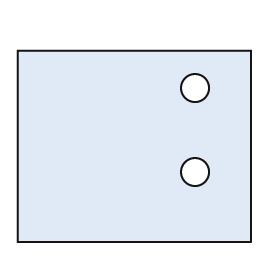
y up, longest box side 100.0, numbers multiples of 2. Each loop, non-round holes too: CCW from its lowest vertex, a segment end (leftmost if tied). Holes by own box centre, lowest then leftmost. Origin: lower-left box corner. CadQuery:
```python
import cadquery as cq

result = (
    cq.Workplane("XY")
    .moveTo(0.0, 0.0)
    .lineTo(100.0, 0.0)
    .lineTo(100.0, 82.0)
    .lineTo(0.0, 82.0)
    .close()
    .moveTo(76.0, 30.0)
    .circle(6.0)
    .moveTo(76.0, 66.0)
    .circle(6.0)
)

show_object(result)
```